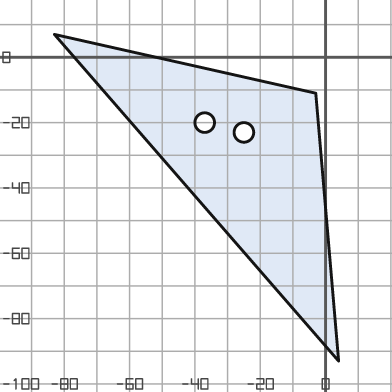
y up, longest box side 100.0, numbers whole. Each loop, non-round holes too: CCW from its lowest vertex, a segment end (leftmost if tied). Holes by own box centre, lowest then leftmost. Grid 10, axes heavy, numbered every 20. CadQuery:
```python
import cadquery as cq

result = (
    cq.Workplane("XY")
    .moveTo(4.0, -93.0)
    .lineTo(-3.0, -11.0)
    .lineTo(-83.0, 7.0)
    .close()
    .moveTo(-25.0, -23.0)
    .circle(3.0)
    .moveTo(-37.0, -20.0)
    .circle(3.0)
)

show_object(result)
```